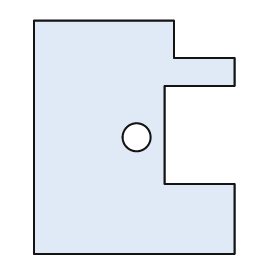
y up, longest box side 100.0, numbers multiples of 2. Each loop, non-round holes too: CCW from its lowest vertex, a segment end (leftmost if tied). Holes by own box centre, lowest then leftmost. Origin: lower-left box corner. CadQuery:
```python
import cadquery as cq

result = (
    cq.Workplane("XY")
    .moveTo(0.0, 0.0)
    .lineTo(86.0, 0.0)
    .lineTo(86.0, 30.0)
    .lineTo(56.0, 30.0)
    .lineTo(56.0, 72.0)
    .lineTo(86.0, 72.0)
    .lineTo(86.0, 84.0)
    .lineTo(60.0, 84.0)
    .lineTo(60.0, 100.0)
    .lineTo(0.0, 100.0)
    .close()
    .moveTo(44.0, 50.0)
    .circle(6.0)
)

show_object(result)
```